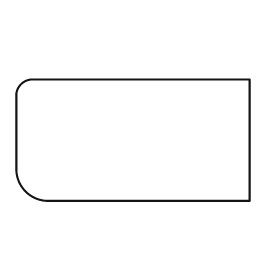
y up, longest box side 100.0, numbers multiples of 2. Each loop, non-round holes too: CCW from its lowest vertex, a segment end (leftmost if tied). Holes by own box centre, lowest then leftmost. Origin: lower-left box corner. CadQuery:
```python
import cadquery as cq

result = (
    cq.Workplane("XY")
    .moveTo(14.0, 0.0)
    .lineTo(100.0, 0.0)
    .lineTo(100.0, 52.0)
    .lineTo(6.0, 52.0)
    .threePointArc((2.0, 50.0), (0.0, 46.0))
    .lineTo(0.0, 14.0)
    .threePointArc((4.0, 4.0), (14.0, 0.0))
    .close()
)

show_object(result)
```